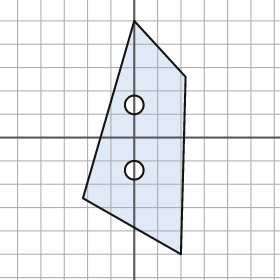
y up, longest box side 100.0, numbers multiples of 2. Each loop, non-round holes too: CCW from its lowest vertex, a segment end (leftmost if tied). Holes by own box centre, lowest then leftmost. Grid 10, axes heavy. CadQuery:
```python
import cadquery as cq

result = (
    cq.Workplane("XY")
    .moveTo(20.0, -50.0)
    .lineTo(22.0, 26.0)
    .lineTo(0.0, 50.0)
    .lineTo(-22.0, -26.0)
    .close()
    .moveTo(0.0, -14.0)
    .circle(4.0)
    .moveTo(0.0, 14.0)
    .circle(4.0)
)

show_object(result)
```